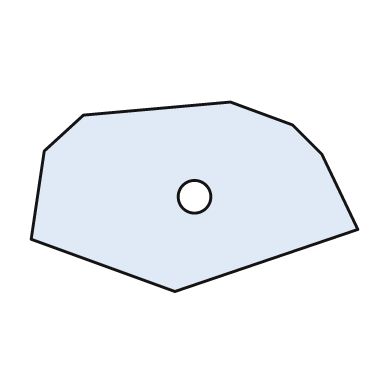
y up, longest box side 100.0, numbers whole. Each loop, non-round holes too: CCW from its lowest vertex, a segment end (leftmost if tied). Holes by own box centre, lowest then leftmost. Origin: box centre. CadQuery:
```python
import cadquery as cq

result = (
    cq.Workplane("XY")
    .moveTo(-6.0, -29.0)
    .lineTo(50.0, -10.0)
    .lineTo(39.0, 13.0)
    .lineTo(30.0, 22.0)
    .lineTo(11.0, 29.0)
    .lineTo(-34.0, 25.0)
    .lineTo(-46.0, 14.0)
    .lineTo(-50.0, -13.0)
    .close()
    .moveTo(0.0, 0.0)
    .circle(5.0)
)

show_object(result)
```